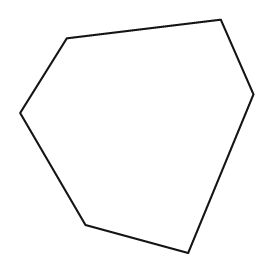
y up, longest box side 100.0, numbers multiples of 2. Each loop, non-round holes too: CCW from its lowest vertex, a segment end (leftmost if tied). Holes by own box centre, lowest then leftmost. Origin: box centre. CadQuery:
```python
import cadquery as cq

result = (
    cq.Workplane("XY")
    .moveTo(22.0, -50.0)
    .lineTo(50.0, 18.0)
    .lineTo(36.0, 50.0)
    .lineTo(-30.0, 42.0)
    .lineTo(-50.0, 10.0)
    .lineTo(-22.0, -38.0)
    .close()
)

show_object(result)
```